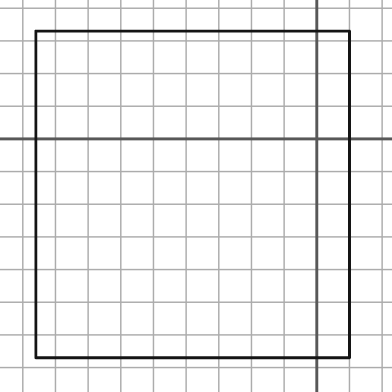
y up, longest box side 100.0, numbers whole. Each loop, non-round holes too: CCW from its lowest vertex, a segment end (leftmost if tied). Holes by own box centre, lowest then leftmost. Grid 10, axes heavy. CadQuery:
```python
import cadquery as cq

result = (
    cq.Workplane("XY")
    .moveTo(-86.0, -67.0)
    .lineTo(10.0, -67.0)
    .lineTo(10.0, 33.0)
    .lineTo(-86.0, 33.0)
    .close()
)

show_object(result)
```